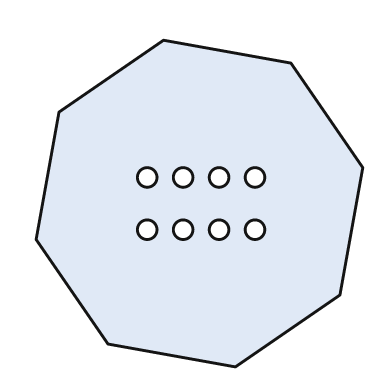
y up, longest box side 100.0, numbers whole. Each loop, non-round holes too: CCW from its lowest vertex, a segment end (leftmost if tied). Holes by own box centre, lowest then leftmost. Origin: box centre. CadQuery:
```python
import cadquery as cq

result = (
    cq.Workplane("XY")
    .moveTo(11.0, -50.0)
    .lineTo(43.0, -28.0)
    .lineTo(50.0, 11.0)
    .lineTo(28.0, 43.0)
    .lineTo(-11.0, 50.0)
    .lineTo(-43.0, 28.0)
    .lineTo(-50.0, -11.0)
    .lineTo(-28.0, -43.0)
    .close()
    .moveTo(-16.0, -8.0)
    .circle(3.0)
    .moveTo(-5.0, -8.0)
    .circle(3.0)
    .moveTo(6.0, -8.0)
    .circle(3.0)
    .moveTo(17.0, -8.0)
    .circle(3.0)
    .moveTo(-16.0, 8.0)
    .circle(3.0)
    .moveTo(-5.0, 8.0)
    .circle(3.0)
    .moveTo(6.0, 8.0)
    .circle(3.0)
    .moveTo(17.0, 8.0)
    .circle(3.0)
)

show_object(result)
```